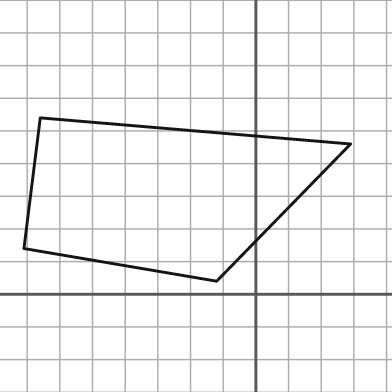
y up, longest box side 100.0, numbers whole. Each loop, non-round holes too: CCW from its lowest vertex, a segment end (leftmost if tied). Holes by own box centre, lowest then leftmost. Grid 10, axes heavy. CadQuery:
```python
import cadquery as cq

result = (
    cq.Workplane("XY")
    .moveTo(-12.0, 4.0)
    .lineTo(29.0, 46.0)
    .lineTo(-66.0, 54.0)
    .lineTo(-71.0, 14.0)
    .close()
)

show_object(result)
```